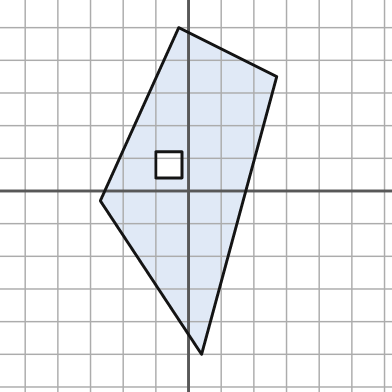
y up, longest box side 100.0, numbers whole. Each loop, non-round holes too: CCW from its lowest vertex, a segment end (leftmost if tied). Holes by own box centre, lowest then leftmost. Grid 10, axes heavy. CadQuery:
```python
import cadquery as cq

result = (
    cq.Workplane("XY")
    .moveTo(4.0, -50.0)
    .lineTo(27.0, 35.0)
    .lineTo(-3.0, 50.0)
    .lineTo(-27.0, -3.0)
    .close()
    .moveTo(-10.0, 4.0)
    .lineTo(-2.0, 4.0)
    .lineTo(-2.0, 12.0)
    .lineTo(-10.0, 12.0)
    .close()
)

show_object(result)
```